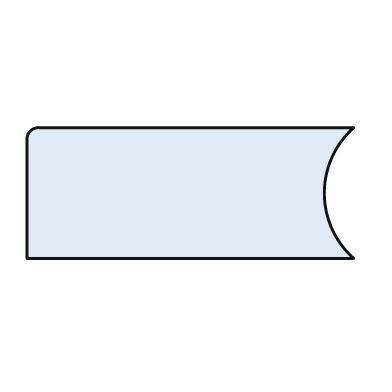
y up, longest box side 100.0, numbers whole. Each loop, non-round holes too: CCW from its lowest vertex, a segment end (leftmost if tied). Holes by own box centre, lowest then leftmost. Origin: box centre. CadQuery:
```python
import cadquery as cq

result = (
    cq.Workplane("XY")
    .moveTo(-50.0, -20.0)
    .lineTo(50.0, -20.0)
    .threePointArc((41.0, 0.0), (50.0, 20.0))
    .lineTo(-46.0, 20.0)
    .threePointArc((-49.0, 19.0), (-50.0, 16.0))
    .close()
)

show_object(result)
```